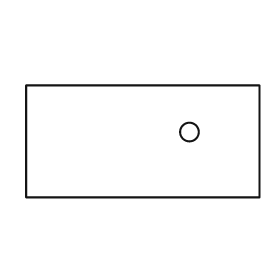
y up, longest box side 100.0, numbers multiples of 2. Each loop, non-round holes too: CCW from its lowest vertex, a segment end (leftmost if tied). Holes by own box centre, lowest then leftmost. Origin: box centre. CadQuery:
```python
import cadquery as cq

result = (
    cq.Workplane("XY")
    .moveTo(-50.0, -24.0)
    .lineTo(50.0, -24.0)
    .lineTo(50.0, 24.0)
    .lineTo(-50.0, 24.0)
    .close()
    .moveTo(20.0, 4.0)
    .circle(4.0)
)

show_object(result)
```